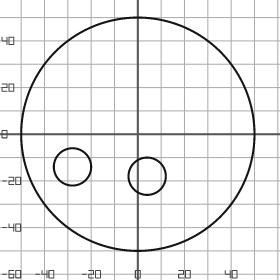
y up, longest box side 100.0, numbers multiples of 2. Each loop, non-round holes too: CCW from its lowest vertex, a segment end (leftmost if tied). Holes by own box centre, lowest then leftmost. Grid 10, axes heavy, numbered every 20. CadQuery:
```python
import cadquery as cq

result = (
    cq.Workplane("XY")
    .moveTo(0.0, 0.0)
    .circle(50.0)
    .moveTo(4.0, -18.0)
    .circle(8.0)
    .moveTo(-28.0, -14.0)
    .circle(8.0)
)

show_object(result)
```